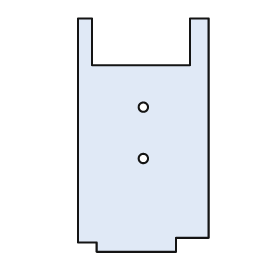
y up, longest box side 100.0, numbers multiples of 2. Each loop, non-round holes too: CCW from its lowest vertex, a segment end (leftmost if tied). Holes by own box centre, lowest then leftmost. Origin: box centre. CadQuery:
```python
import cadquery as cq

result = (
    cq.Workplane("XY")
    .moveTo(-20.0, -50.0)
    .lineTo(14.0, -50.0)
    .lineTo(14.0, -44.0)
    .lineTo(28.0, -44.0)
    .lineTo(28.0, 50.0)
    .lineTo(20.0, 50.0)
    .lineTo(20.0, 30.0)
    .lineTo(-22.0, 30.0)
    .lineTo(-22.0, 50.0)
    .lineTo(-28.0, 50.0)
    .lineTo(-28.0, -46.0)
    .lineTo(-20.0, -46.0)
    .close()
    .moveTo(0.0, -10.0)
    .circle(2.0)
    .moveTo(0.0, 12.0)
    .circle(2.0)
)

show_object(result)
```